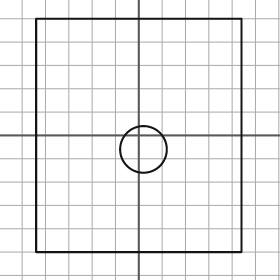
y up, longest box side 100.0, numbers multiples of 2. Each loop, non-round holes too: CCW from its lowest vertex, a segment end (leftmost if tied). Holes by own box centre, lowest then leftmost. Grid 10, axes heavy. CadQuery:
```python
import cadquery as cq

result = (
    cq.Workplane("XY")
    .moveTo(-44.0, -50.0)
    .lineTo(44.0, -50.0)
    .lineTo(44.0, 50.0)
    .lineTo(-44.0, 50.0)
    .close()
    .moveTo(2.0, -6.0)
    .circle(10.0)
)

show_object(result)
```